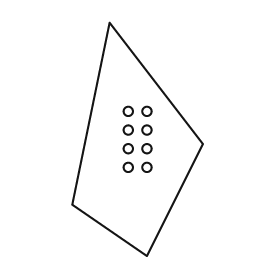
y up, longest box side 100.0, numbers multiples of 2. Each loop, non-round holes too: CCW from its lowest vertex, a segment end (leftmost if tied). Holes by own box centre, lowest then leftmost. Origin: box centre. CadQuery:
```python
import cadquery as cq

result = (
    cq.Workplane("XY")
    .moveTo(4.0, -50.0)
    .lineTo(28.0, -2.0)
    .lineTo(-12.0, 50.0)
    .lineTo(-28.0, -28.0)
    .close()
    .moveTo(-4.0, -12.0)
    .circle(2.0)
    .moveTo(4.0, -12.0)
    .circle(2.0)
    .moveTo(-4.0, -4.0)
    .circle(2.0)
    .moveTo(4.0, -4.0)
    .circle(2.0)
    .moveTo(-4.0, 4.0)
    .circle(2.0)
    .moveTo(4.0, 4.0)
    .circle(2.0)
    .moveTo(-4.0, 12.0)
    .circle(2.0)
    .moveTo(4.0, 12.0)
    .circle(2.0)
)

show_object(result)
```